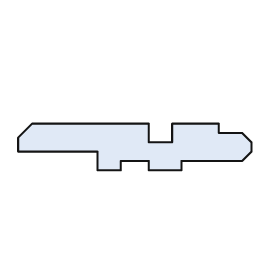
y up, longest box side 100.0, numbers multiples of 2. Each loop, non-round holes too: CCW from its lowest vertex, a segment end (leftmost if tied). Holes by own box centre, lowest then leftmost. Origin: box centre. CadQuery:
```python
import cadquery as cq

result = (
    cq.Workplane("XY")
    .moveTo(-16.0, -10.0)
    .lineTo(-6.0, -10.0)
    .lineTo(-6.0, -6.0)
    .lineTo(6.0, -6.0)
    .lineTo(6.0, -10.0)
    .lineTo(20.0, -10.0)
    .lineTo(20.0, -6.0)
    .lineTo(46.0, -6.0)
    .lineTo(50.0, -2.0)
    .lineTo(50.0, 2.0)
    .lineTo(46.0, 6.0)
    .lineTo(36.0, 6.0)
    .lineTo(36.0, 10.0)
    .lineTo(16.0, 10.0)
    .lineTo(16.0, 2.0)
    .lineTo(6.0, 2.0)
    .lineTo(6.0, 10.0)
    .lineTo(-44.0, 10.0)
    .lineTo(-50.0, 4.0)
    .lineTo(-50.0, -2.0)
    .lineTo(-16.0, -2.0)
    .close()
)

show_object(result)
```